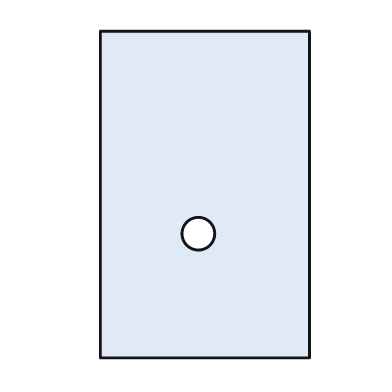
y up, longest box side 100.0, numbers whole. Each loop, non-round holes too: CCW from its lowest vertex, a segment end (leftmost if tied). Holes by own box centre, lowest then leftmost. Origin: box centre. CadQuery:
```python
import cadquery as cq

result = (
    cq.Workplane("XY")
    .moveTo(-32.0, -50.0)
    .lineTo(32.0, -50.0)
    .lineTo(32.0, 50.0)
    .lineTo(-32.0, 50.0)
    .close()
    .moveTo(-2.0, -12.0)
    .circle(5.0)
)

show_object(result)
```